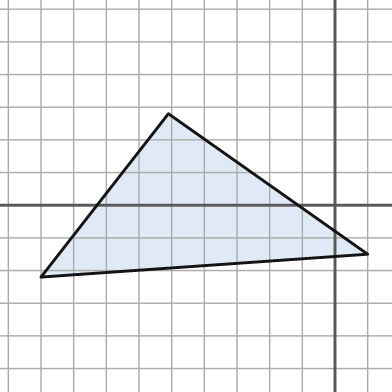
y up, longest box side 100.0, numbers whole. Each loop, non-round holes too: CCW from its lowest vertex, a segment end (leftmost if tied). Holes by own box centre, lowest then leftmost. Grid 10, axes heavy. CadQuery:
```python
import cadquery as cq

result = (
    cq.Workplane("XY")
    .moveTo(-90.0, -22.0)
    .lineTo(10.0, -15.0)
    .lineTo(-51.0, 28.0)
    .close()
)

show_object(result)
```